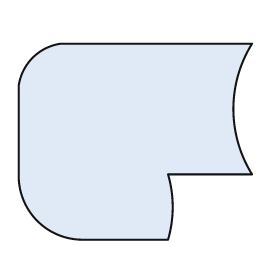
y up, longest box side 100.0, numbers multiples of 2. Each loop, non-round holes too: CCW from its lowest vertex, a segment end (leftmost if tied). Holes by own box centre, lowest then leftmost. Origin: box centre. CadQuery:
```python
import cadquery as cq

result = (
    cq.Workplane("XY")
    .moveTo(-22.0, -42.0)
    .lineTo(14.0, -42.0)
    .threePointArc((16.0, -28.0), (14.0, -14.0))
    .lineTo(50.0, -14.0)
    .threePointArc((42.0, 14.0), (50.0, 42.0))
    .lineTo(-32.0, 42.0)
    .threePointArc((-44.0, 36.0), (-50.0, 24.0))
    .lineTo(-50.0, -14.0)
    .threePointArc((-42.0, -34.0), (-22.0, -42.0))
    .close()
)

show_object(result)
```